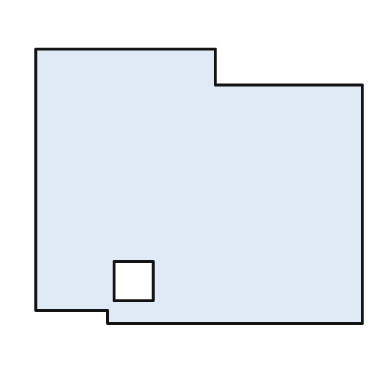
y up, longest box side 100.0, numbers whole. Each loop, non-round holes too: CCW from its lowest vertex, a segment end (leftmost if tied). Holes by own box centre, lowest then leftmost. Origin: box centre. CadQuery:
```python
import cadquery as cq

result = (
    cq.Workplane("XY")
    .moveTo(-28.0, -42.0)
    .lineTo(50.0, -42.0)
    .lineTo(50.0, 31.0)
    .lineTo(5.0, 31.0)
    .lineTo(5.0, 42.0)
    .lineTo(-50.0, 42.0)
    .lineTo(-50.0, -38.0)
    .lineTo(-28.0, -38.0)
    .close()
    .moveTo(-26.0, -35.0)
    .lineTo(-14.0, -35.0)
    .lineTo(-14.0, -23.0)
    .lineTo(-26.0, -23.0)
    .close()
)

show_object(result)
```